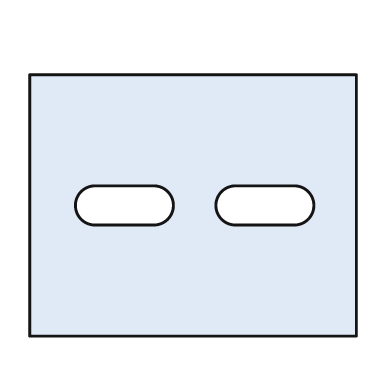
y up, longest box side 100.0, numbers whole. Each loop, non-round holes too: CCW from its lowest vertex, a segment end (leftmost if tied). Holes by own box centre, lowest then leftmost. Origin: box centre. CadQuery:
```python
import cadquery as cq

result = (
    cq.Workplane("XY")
    .moveTo(-50.0, -40.0)
    .lineTo(50.0, -40.0)
    .lineTo(50.0, 40.0)
    .lineTo(-50.0, 40.0)
    .close()
    .moveTo(-30.0, -6.0)
    .lineTo(-12.0, -6.0)
    .threePointArc((-6.0, 0.0), (-12.0, 6.0))
    .lineTo(-30.0, 6.0)
    .threePointArc((-36.0, 0.0), (-30.0, -6.0))
    .close()
    .moveTo(13.0, -6.0)
    .lineTo(31.0, -6.0)
    .threePointArc((37.0, 0.0), (31.0, 6.0))
    .lineTo(13.0, 6.0)
    .threePointArc((7.0, 0.0), (13.0, -6.0))
    .close()
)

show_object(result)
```